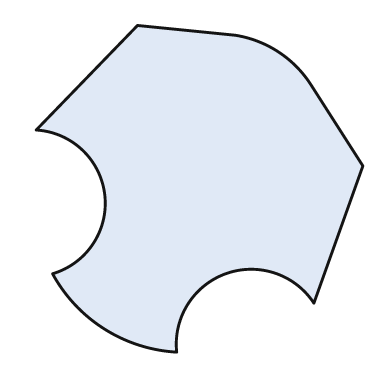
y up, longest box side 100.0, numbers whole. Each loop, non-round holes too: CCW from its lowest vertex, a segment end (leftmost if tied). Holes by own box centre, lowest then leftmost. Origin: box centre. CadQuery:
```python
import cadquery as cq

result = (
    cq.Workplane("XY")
    .moveTo(-7.0, -50.0)
    .threePointArc((8.0, -26.0), (35.0, -35.0))
    .lineTo(50.0, 7.0)
    .lineTo(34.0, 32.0)
    .threePointArc((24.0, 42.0), (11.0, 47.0))
    .lineTo(-19.0, 50.0)
    .lineTo(-50.0, 18.0)
    .threePointArc((-29.0, -2.0), (-45.0, -26.0))
    .threePointArc((-29.0, -43.0), (-7.0, -50.0))
    .close()
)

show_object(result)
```